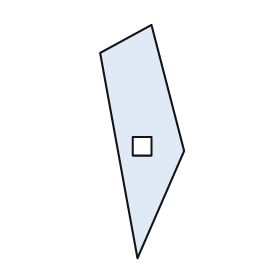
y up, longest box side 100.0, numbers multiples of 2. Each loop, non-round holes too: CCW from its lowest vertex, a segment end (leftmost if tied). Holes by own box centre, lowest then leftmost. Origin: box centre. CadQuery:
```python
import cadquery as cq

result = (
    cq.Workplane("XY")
    .moveTo(-2.0, -50.0)
    .lineTo(18.0, -4.0)
    .lineTo(4.0, 50.0)
    .lineTo(-18.0, 38.0)
    .close()
    .moveTo(-4.0, -6.0)
    .lineTo(4.0, -6.0)
    .lineTo(4.0, 2.0)
    .lineTo(-4.0, 2.0)
    .close()
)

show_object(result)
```